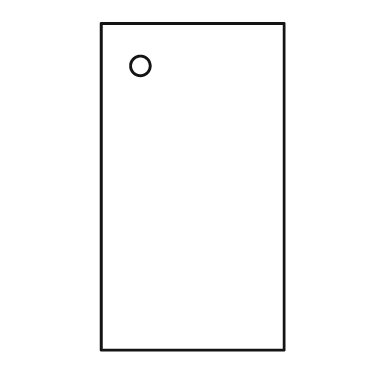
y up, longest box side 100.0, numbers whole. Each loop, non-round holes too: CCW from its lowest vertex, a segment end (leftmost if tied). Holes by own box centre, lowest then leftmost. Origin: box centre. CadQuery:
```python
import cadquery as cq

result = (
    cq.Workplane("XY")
    .moveTo(-28.0, -50.0)
    .lineTo(28.0, -50.0)
    .lineTo(28.0, 50.0)
    .lineTo(-28.0, 50.0)
    .close()
    .moveTo(-16.0, 37.0)
    .circle(3.0)
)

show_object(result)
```